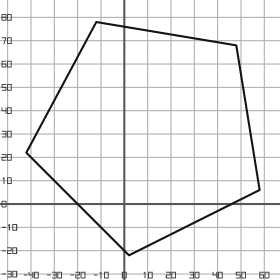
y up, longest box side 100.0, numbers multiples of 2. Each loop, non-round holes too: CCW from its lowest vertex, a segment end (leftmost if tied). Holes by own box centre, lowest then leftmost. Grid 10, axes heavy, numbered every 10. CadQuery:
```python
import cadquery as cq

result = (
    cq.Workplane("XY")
    .moveTo(2.0, -22.0)
    .lineTo(58.0, 6.0)
    .lineTo(48.0, 68.0)
    .lineTo(-12.0, 78.0)
    .lineTo(-42.0, 22.0)
    .close()
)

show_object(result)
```